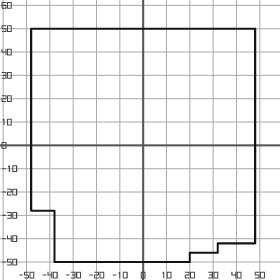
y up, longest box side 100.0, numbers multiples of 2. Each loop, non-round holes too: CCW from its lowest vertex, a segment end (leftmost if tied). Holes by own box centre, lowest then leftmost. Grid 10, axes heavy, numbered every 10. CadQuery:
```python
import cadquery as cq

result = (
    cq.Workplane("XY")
    .moveTo(-38.0, -50.0)
    .lineTo(20.0, -50.0)
    .lineTo(20.0, -46.0)
    .lineTo(32.0, -46.0)
    .lineTo(32.0, -42.0)
    .lineTo(48.0, -42.0)
    .lineTo(48.0, 50.0)
    .lineTo(-48.0, 50.0)
    .lineTo(-48.0, -28.0)
    .lineTo(-38.0, -28.0)
    .close()
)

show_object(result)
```